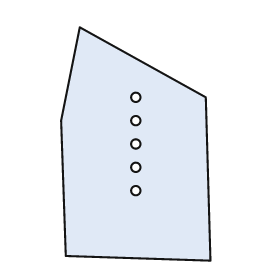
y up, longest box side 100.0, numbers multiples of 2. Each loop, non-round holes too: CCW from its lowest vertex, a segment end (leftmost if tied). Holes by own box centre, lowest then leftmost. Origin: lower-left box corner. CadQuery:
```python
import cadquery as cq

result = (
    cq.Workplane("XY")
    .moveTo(64.0, 0.0)
    .lineTo(62.0, 70.0)
    .lineTo(8.0, 100.0)
    .lineTo(0.0, 60.0)
    .lineTo(2.0, 2.0)
    .close()
    .moveTo(32.0, 30.0)
    .circle(2.0)
    .moveTo(32.0, 40.0)
    .circle(2.0)
    .moveTo(32.0, 50.0)
    .circle(2.0)
    .moveTo(32.0, 60.0)
    .circle(2.0)
    .moveTo(32.0, 70.0)
    .circle(2.0)
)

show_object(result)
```